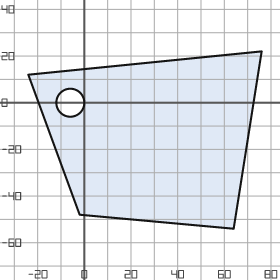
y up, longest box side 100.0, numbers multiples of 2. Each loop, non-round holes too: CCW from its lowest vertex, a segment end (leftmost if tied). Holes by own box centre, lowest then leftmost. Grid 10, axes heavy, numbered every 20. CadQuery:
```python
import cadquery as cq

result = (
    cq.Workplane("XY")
    .moveTo(64.0, -54.0)
    .lineTo(76.0, 22.0)
    .lineTo(-24.0, 12.0)
    .lineTo(-2.0, -48.0)
    .close()
    .moveTo(-6.0, 0.0)
    .circle(6.0)
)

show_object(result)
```